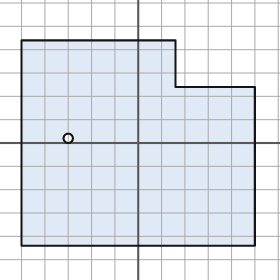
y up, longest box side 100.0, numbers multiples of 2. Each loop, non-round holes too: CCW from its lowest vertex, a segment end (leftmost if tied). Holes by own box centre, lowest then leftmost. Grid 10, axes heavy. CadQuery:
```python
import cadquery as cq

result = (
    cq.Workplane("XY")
    .moveTo(-50.0, -44.0)
    .lineTo(50.0, -44.0)
    .lineTo(50.0, 24.0)
    .lineTo(16.0, 24.0)
    .lineTo(16.0, 44.0)
    .lineTo(-50.0, 44.0)
    .close()
    .moveTo(-30.0, 2.0)
    .circle(2.0)
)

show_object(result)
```